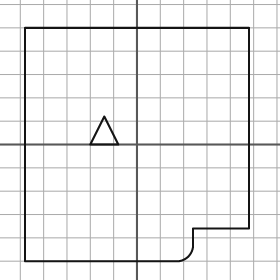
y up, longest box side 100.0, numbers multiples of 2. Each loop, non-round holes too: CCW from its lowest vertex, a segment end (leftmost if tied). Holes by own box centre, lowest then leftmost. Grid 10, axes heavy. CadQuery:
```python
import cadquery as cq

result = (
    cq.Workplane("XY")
    .moveTo(-48.0, -50.0)
    .lineTo(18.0, -50.0)
    .threePointArc((22.0, -48.0), (24.0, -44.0))
    .lineTo(24.0, -36.0)
    .lineTo(48.0, -36.0)
    .lineTo(48.0, 50.0)
    .lineTo(-48.0, 50.0)
    .close()
    .moveTo(-20.0, 0.0)
    .lineTo(-8.0, 0.0)
    .lineTo(-14.0, 12.0)
    .close()
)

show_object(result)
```